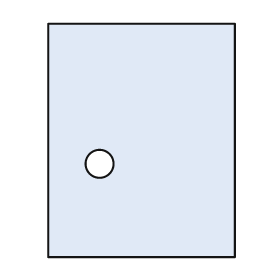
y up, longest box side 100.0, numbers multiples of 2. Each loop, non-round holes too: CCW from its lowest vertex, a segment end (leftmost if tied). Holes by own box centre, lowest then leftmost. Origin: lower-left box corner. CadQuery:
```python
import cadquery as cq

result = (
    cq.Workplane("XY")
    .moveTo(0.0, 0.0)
    .lineTo(80.0, 0.0)
    .lineTo(80.0, 100.0)
    .lineTo(0.0, 100.0)
    .close()
    .moveTo(22.0, 40.0)
    .circle(6.0)
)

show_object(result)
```